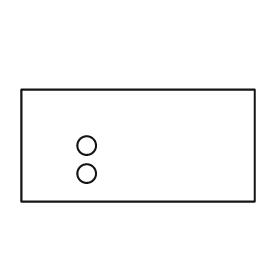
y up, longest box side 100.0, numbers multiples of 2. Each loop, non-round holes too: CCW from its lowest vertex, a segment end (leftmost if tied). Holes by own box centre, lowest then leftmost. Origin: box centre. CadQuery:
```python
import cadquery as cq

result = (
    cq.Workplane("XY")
    .moveTo(-50.0, -24.0)
    .lineTo(50.0, -24.0)
    .lineTo(50.0, 24.0)
    .lineTo(-50.0, 24.0)
    .close()
    .moveTo(-22.0, -12.0)
    .circle(4.0)
    .moveTo(-22.0, 0.0)
    .circle(4.0)
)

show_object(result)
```